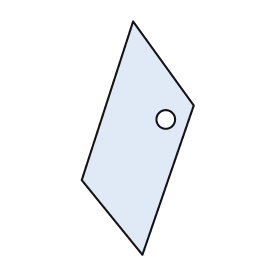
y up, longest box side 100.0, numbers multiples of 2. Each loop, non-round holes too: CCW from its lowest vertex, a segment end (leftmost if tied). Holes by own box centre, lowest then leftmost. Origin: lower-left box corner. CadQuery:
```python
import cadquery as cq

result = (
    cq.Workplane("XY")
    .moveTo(26.0, 0.0)
    .lineTo(48.0, 64.0)
    .lineTo(22.0, 100.0)
    .lineTo(0.0, 32.0)
    .close()
    .moveTo(36.0, 58.0)
    .circle(4.0)
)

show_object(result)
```